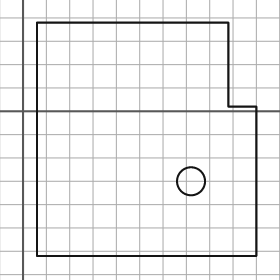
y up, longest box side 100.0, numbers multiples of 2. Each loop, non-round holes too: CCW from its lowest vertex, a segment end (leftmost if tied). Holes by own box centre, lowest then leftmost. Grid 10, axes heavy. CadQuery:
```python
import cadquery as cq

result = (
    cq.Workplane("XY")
    .moveTo(6.0, -62.0)
    .lineTo(100.0, -62.0)
    .lineTo(100.0, 2.0)
    .lineTo(88.0, 2.0)
    .lineTo(88.0, 38.0)
    .lineTo(6.0, 38.0)
    .close()
    .moveTo(72.0, -30.0)
    .circle(6.0)
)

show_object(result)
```